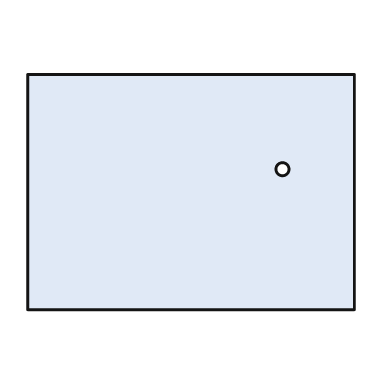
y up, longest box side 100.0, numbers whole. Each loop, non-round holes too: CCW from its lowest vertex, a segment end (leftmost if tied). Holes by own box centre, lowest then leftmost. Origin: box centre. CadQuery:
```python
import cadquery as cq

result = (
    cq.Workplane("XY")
    .moveTo(-50.0, -36.0)
    .lineTo(50.0, -36.0)
    .lineTo(50.0, 36.0)
    .lineTo(-50.0, 36.0)
    .close()
    .moveTo(28.0, 7.0)
    .circle(2.0)
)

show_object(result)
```